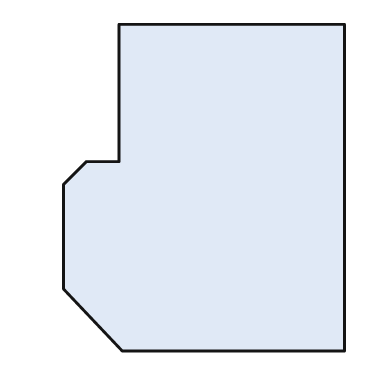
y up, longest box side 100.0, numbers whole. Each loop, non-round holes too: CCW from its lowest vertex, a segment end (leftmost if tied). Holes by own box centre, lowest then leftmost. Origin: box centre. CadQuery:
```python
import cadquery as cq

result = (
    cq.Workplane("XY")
    .moveTo(-25.0, -50.0)
    .lineTo(43.0, -50.0)
    .lineTo(43.0, 50.0)
    .lineTo(-26.0, 50.0)
    .lineTo(-26.0, 8.0)
    .lineTo(-36.0, 8.0)
    .lineTo(-43.0, 1.0)
    .lineTo(-43.0, -31.0)
    .close()
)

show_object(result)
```